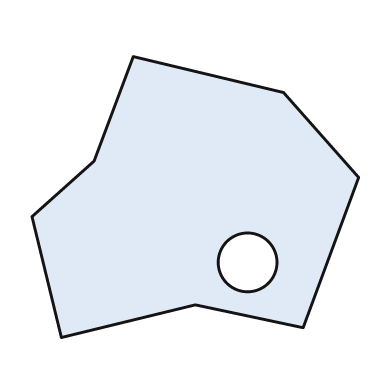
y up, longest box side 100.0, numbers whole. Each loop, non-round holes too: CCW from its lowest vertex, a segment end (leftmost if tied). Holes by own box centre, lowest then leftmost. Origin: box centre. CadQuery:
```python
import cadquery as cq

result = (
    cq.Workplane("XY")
    .moveTo(-41.0, -43.0)
    .lineTo(0.0, -33.0)
    .lineTo(33.0, -40.0)
    .lineTo(50.0, 6.0)
    .lineTo(27.0, 32.0)
    .lineTo(-19.0, 43.0)
    .lineTo(-31.0, 11.0)
    .lineTo(-50.0, -6.0)
    .close()
    .moveTo(16.0, -20.0)
    .circle(9.0)
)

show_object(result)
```